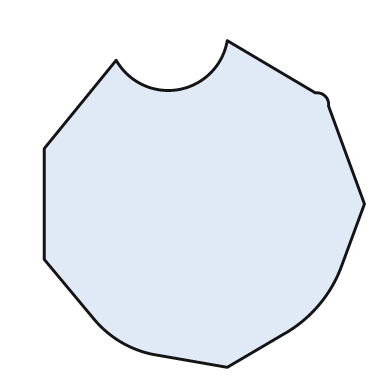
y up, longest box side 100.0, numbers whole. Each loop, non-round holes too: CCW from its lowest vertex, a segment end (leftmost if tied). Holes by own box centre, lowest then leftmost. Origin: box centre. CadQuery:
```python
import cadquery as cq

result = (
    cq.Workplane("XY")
    .moveTo(7.0, -50.0)
    .lineTo(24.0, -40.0)
    .threePointArc((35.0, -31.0), (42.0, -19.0))
    .lineTo(49.0, 0.0)
    .lineTo(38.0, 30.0)
    .threePointArc((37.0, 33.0), (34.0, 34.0))
    .lineTo(7.0, 50.0)
    .threePointArc((-8.0, 35.0), (-27.0, 44.0))
    .lineTo(-49.0, 17.0)
    .lineTo(-49.0, -17.0)
    .lineTo(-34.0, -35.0)
    .threePointArc((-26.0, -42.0), (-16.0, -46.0))
    .close()
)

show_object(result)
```